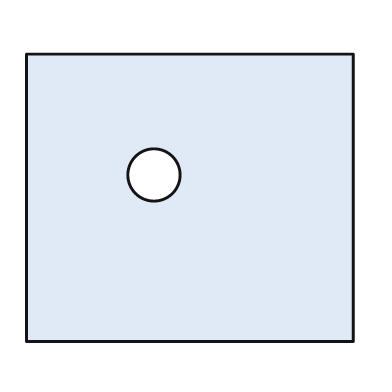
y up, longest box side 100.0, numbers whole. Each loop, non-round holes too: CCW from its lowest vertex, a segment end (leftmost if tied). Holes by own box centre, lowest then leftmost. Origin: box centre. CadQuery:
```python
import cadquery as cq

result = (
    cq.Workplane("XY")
    .moveTo(-50.0, -44.0)
    .lineTo(50.0, -44.0)
    .lineTo(50.0, 44.0)
    .lineTo(-50.0, 44.0)
    .close()
    .moveTo(-11.0, 7.0)
    .circle(8.0)
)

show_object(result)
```